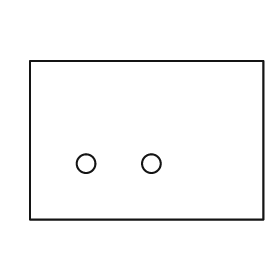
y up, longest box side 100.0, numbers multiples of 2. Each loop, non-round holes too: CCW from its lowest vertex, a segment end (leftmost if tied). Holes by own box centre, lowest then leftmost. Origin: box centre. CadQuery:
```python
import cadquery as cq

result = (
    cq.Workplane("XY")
    .moveTo(-50.0, -34.0)
    .lineTo(50.0, -34.0)
    .lineTo(50.0, 34.0)
    .lineTo(-50.0, 34.0)
    .close()
    .moveTo(-26.0, -10.0)
    .circle(4.0)
    .moveTo(2.0, -10.0)
    .circle(4.0)
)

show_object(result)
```